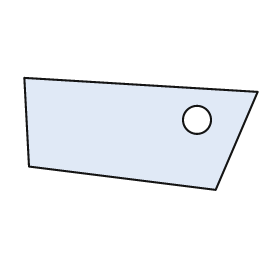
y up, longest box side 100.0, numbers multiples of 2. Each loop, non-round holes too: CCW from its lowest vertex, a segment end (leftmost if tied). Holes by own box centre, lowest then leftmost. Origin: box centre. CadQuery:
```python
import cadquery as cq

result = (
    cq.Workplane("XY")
    .moveTo(32.0, -24.0)
    .lineTo(50.0, 18.0)
    .lineTo(-50.0, 24.0)
    .lineTo(-48.0, -14.0)
    .close()
    .moveTo(24.0, 6.0)
    .circle(6.0)
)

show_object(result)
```